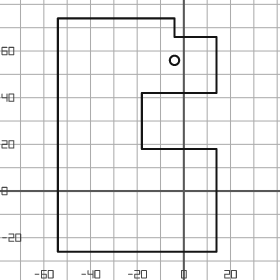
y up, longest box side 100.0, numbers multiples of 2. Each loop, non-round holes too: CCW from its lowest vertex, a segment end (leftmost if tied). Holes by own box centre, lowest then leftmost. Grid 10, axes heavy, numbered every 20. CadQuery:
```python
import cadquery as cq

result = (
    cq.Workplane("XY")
    .moveTo(-54.0, -26.0)
    .lineTo(14.0, -26.0)
    .lineTo(14.0, 18.0)
    .lineTo(-18.0, 18.0)
    .lineTo(-18.0, 42.0)
    .lineTo(14.0, 42.0)
    .lineTo(14.0, 66.0)
    .lineTo(-4.0, 66.0)
    .lineTo(-4.0, 74.0)
    .lineTo(-54.0, 74.0)
    .close()
    .moveTo(-4.0, 56.0)
    .circle(2.0)
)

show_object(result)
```